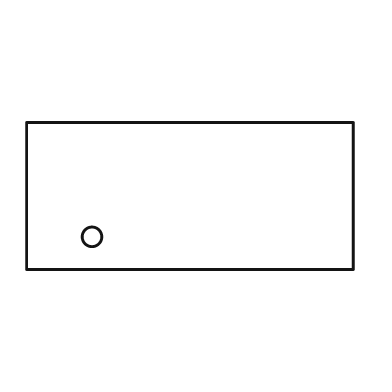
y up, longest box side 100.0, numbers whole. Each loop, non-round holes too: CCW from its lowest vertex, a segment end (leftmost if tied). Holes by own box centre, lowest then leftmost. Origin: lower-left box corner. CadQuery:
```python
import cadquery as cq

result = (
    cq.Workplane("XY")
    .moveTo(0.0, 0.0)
    .lineTo(100.0, 0.0)
    .lineTo(100.0, 45.0)
    .lineTo(0.0, 45.0)
    .close()
    .moveTo(20.0, 10.0)
    .circle(3.0)
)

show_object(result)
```